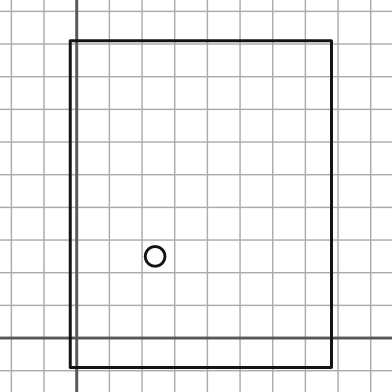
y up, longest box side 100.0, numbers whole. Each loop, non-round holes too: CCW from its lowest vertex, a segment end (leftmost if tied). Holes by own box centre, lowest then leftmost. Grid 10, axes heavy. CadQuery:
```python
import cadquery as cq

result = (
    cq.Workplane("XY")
    .moveTo(-2.0, -9.0)
    .lineTo(78.0, -9.0)
    .lineTo(78.0, 91.0)
    .lineTo(-2.0, 91.0)
    .close()
    .moveTo(24.0, 25.0)
    .circle(3.0)
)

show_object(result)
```